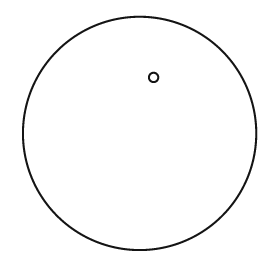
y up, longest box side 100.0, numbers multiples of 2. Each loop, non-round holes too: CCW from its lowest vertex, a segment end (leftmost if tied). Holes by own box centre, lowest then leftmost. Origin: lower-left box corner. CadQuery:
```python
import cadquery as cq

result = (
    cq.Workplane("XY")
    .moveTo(50.0, 50.0)
    .circle(50.0)
    .moveTo(56.0, 74.0)
    .circle(2.0)
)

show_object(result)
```